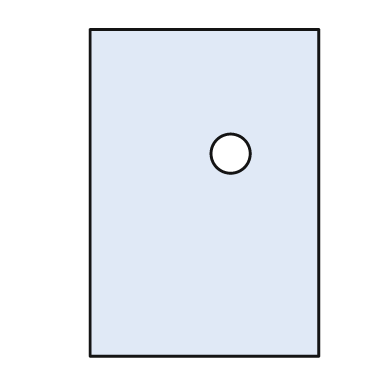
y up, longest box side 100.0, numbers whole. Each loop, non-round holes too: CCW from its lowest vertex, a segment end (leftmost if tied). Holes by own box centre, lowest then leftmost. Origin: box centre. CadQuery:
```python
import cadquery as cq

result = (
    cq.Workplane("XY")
    .moveTo(-35.0, -50.0)
    .lineTo(35.0, -50.0)
    .lineTo(35.0, 50.0)
    .lineTo(-35.0, 50.0)
    .close()
    .moveTo(8.0, 12.0)
    .circle(6.0)
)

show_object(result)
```